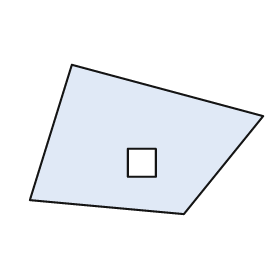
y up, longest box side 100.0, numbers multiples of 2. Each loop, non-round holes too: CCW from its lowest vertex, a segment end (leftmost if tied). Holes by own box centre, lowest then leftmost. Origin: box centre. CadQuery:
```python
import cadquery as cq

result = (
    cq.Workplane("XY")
    .moveTo(16.0, -32.0)
    .lineTo(50.0, 10.0)
    .lineTo(-32.0, 32.0)
    .lineTo(-50.0, -26.0)
    .close()
    .moveTo(-8.0, -16.0)
    .lineTo(4.0, -16.0)
    .lineTo(4.0, -4.0)
    .lineTo(-8.0, -4.0)
    .close()
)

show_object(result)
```